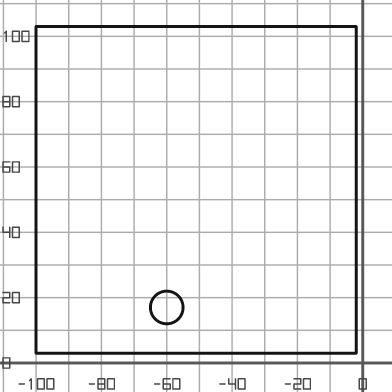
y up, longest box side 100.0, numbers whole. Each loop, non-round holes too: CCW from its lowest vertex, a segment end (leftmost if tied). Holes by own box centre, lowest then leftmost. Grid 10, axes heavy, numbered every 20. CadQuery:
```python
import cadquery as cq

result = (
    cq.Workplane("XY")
    .moveTo(-100.0, 3.0)
    .lineTo(-2.0, 3.0)
    .lineTo(-2.0, 103.0)
    .lineTo(-100.0, 103.0)
    .close()
    .moveTo(-60.0, 17.0)
    .circle(5.0)
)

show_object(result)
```